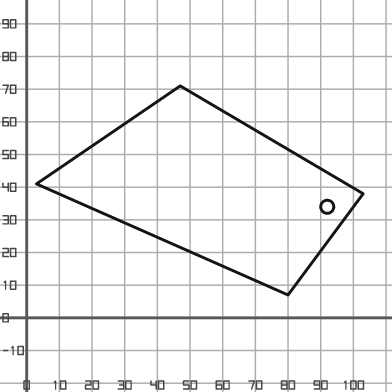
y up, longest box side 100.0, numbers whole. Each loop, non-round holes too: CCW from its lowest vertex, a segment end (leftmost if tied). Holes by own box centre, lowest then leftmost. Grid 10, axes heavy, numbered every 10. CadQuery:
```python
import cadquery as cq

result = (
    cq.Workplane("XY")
    .moveTo(80.0, 7.0)
    .lineTo(103.0, 38.0)
    .lineTo(47.0, 71.0)
    .lineTo(3.0, 41.0)
    .close()
    .moveTo(92.0, 34.0)
    .circle(2.0)
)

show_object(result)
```